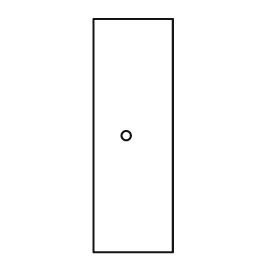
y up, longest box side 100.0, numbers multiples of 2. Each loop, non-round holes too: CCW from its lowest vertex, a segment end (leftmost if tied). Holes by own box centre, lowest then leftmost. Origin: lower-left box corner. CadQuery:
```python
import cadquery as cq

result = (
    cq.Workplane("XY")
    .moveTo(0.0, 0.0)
    .lineTo(34.0, 0.0)
    .lineTo(34.0, 100.0)
    .lineTo(0.0, 100.0)
    .close()
    .moveTo(14.0, 50.0)
    .circle(2.0)
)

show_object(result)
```